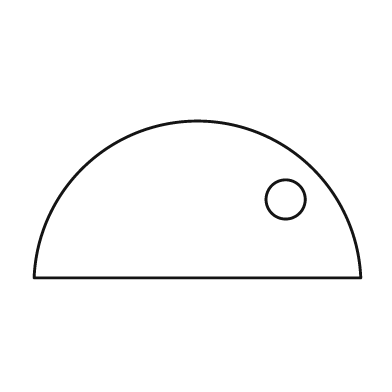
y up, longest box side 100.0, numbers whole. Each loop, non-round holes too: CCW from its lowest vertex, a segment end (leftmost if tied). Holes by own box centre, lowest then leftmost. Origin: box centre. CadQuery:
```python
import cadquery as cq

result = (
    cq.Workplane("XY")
    .moveTo(-50.0, -24.0)
    .lineTo(50.0, -24.0)
    .threePointArc((0.0, 24.0), (-50.0, -24.0))
    .close()
    .moveTo(27.0, 0.0)
    .circle(6.0)
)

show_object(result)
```